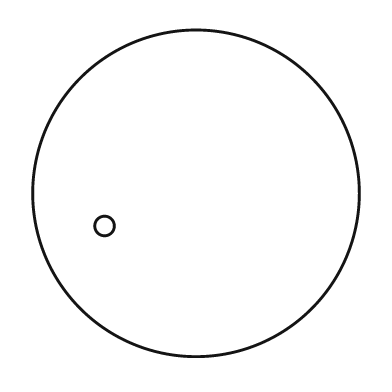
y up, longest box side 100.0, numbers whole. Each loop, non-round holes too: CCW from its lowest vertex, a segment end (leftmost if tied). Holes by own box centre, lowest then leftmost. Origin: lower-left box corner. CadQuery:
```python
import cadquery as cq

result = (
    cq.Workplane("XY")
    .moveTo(50.0, 50.0)
    .circle(50.0)
    .moveTo(22.0, 40.0)
    .circle(3.0)
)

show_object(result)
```